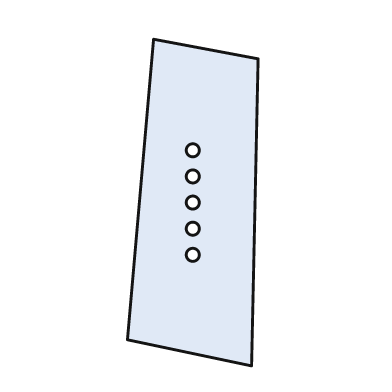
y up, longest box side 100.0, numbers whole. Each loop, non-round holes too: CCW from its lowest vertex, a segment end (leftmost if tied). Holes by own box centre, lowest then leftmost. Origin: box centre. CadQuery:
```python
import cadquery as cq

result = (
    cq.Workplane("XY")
    .moveTo(18.0, -50.0)
    .lineTo(20.0, 44.0)
    .lineTo(-12.0, 50.0)
    .lineTo(-20.0, -42.0)
    .close()
    .moveTo(0.0, -16.0)
    .circle(2.0)
    .moveTo(0.0, -8.0)
    .circle(2.0)
    .moveTo(0.0, 0.0)
    .circle(2.0)
    .moveTo(0.0, 8.0)
    .circle(2.0)
    .moveTo(0.0, 16.0)
    .circle(2.0)
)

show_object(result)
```